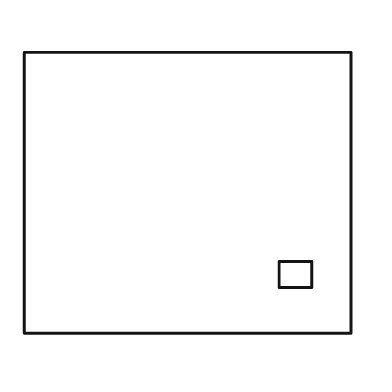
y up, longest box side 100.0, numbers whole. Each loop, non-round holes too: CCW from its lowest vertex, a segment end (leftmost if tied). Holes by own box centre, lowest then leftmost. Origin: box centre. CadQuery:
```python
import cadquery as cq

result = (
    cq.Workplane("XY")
    .moveTo(-50.0, -43.0)
    .lineTo(50.0, -43.0)
    .lineTo(50.0, 43.0)
    .lineTo(-50.0, 43.0)
    .close()
    .moveTo(28.0, -29.0)
    .lineTo(38.0, -29.0)
    .lineTo(38.0, -21.0)
    .lineTo(28.0, -21.0)
    .close()
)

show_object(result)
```